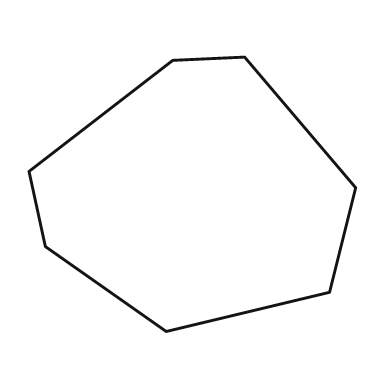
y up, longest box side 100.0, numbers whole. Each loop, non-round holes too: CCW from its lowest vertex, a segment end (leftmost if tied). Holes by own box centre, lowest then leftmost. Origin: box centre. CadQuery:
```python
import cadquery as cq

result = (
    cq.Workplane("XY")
    .moveTo(-8.0, -42.0)
    .lineTo(42.0, -30.0)
    .lineTo(50.0, 2.0)
    .lineTo(16.0, 42.0)
    .lineTo(-6.0, 41.0)
    .lineTo(-50.0, 7.0)
    .lineTo(-45.0, -16.0)
    .close()
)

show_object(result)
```